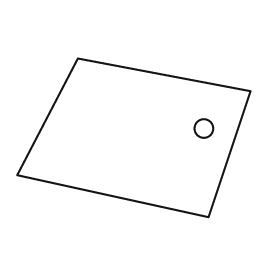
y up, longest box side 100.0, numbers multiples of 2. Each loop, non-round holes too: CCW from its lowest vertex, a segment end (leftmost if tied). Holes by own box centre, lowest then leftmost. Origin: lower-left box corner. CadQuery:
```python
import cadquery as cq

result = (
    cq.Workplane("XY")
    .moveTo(82.0, 0.0)
    .lineTo(100.0, 54.0)
    .lineTo(26.0, 68.0)
    .lineTo(0.0, 18.0)
    .close()
    .moveTo(80.0, 38.0)
    .circle(4.0)
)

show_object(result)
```